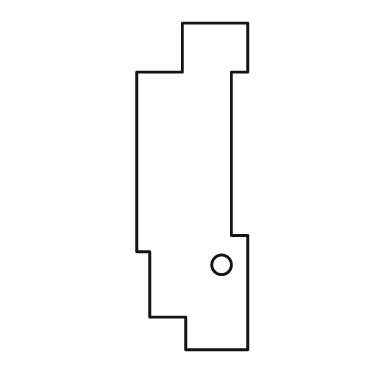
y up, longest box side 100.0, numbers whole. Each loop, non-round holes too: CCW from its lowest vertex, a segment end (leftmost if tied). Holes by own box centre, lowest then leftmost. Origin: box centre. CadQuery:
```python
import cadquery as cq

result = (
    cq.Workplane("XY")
    .moveTo(-2.0, -50.0)
    .lineTo(17.0, -50.0)
    .lineTo(17.0, -15.0)
    .lineTo(12.0, -15.0)
    .lineTo(12.0, 35.0)
    .lineTo(17.0, 35.0)
    .lineTo(17.0, 50.0)
    .lineTo(-3.0, 50.0)
    .lineTo(-3.0, 35.0)
    .lineTo(-17.0, 35.0)
    .lineTo(-17.0, -20.0)
    .lineTo(-13.0, -20.0)
    .lineTo(-13.0, -40.0)
    .lineTo(-2.0, -40.0)
    .close()
    .moveTo(9.0, -24.0)
    .circle(3.0)
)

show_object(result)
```